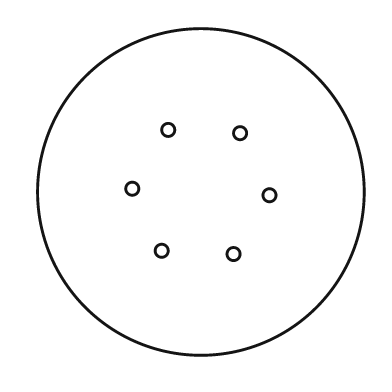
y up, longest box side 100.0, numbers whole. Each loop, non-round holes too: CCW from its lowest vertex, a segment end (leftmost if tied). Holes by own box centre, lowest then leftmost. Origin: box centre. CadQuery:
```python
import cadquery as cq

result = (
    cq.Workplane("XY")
    .moveTo(0.0, 0.0)
    .circle(50.0)
    .moveTo(10.0, -19.0)
    .circle(2.0)
    .moveTo(-12.0, -18.0)
    .circle(2.0)
    .moveTo(21.0, -1.0)
    .circle(2.0)
    .moveTo(-21.0, 1.0)
    .circle(2.0)
    .moveTo(12.0, 18.0)
    .circle(2.0)
    .moveTo(-10.0, 19.0)
    .circle(2.0)
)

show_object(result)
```